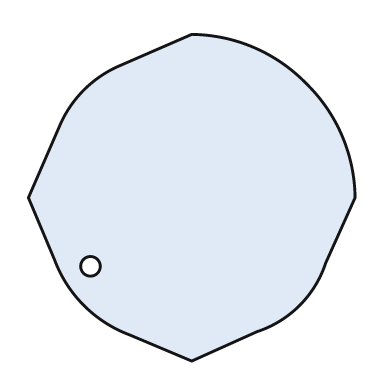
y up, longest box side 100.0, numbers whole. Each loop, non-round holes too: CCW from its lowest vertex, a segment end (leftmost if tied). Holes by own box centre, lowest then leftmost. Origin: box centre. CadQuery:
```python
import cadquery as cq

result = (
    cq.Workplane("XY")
    .moveTo(0.0, -50.0)
    .lineTo(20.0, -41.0)
    .threePointArc((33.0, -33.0), (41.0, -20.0))
    .lineTo(50.0, 0.0)
    .threePointArc((46.0, 19.0), (35.0, 35.0))
    .threePointArc((19.0, 46.0), (0.0, 50.0))
    .lineTo(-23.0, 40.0)
    .threePointArc((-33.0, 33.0), (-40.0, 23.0))
    .lineTo(-50.0, 0.0)
    .lineTo(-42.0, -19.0)
    .threePointArc((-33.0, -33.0), (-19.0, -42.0))
    .close()
    .moveTo(-31.0, -21.0)
    .circle(3.0)
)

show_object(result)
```